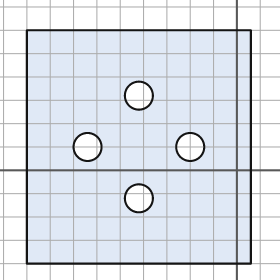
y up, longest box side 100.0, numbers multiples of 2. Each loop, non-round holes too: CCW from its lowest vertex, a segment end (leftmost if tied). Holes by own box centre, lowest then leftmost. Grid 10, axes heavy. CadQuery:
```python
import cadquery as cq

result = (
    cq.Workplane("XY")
    .moveTo(-90.0, -40.0)
    .lineTo(6.0, -40.0)
    .lineTo(6.0, 60.0)
    .lineTo(-90.0, 60.0)
    .close()
    .moveTo(-42.0, -12.0)
    .circle(6.0)
    .moveTo(-64.0, 10.0)
    .circle(6.0)
    .moveTo(-20.0, 10.0)
    .circle(6.0)
    .moveTo(-42.0, 32.0)
    .circle(6.0)
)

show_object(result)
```